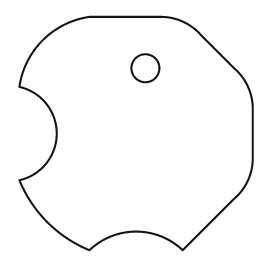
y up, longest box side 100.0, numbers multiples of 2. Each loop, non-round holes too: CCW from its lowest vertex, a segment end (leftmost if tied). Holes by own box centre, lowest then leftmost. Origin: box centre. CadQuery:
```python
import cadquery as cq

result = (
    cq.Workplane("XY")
    .moveTo(-20.0, -50.0)
    .threePointArc((0.0, -42.0), (20.0, -50.0))
    .lineTo(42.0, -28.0)
    .threePointArc((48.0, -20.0), (50.0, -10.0))
    .lineTo(50.0, 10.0)
    .threePointArc((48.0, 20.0), (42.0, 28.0))
    .lineTo(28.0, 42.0)
    .threePointArc((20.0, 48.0), (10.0, 50.0))
    .lineTo(-20.0, 50.0)
    .threePointArc((-40.0, 40.0), (-50.0, 20.0))
    .threePointArc((-34.0, 0.0), (-50.0, -20.0))
    .threePointArc((-38.0, -38.0), (-20.0, -50.0))
    .close()
    .moveTo(4.0, 28.0)
    .circle(6.0)
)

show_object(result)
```